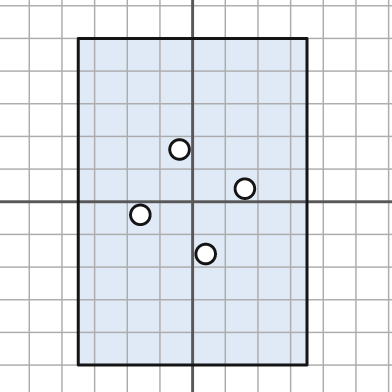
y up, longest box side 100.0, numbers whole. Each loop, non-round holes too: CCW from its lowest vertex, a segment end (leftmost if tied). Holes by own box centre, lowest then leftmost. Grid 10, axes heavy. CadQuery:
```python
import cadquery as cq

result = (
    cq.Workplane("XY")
    .moveTo(-35.0, -50.0)
    .lineTo(35.0, -50.0)
    .lineTo(35.0, 50.0)
    .lineTo(-35.0, 50.0)
    .close()
    .moveTo(4.0, -16.0)
    .circle(3.0)
    .moveTo(-16.0, -4.0)
    .circle(3.0)
    .moveTo(16.0, 4.0)
    .circle(3.0)
    .moveTo(-4.0, 16.0)
    .circle(3.0)
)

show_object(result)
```